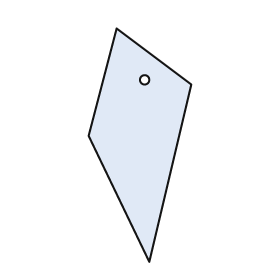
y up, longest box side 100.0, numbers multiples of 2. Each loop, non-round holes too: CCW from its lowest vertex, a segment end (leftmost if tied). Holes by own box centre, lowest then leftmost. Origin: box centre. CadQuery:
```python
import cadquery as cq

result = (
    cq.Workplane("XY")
    .moveTo(4.0, -50.0)
    .lineTo(22.0, 26.0)
    .lineTo(-10.0, 50.0)
    .lineTo(-22.0, 4.0)
    .close()
    .moveTo(2.0, 28.0)
    .circle(2.0)
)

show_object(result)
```